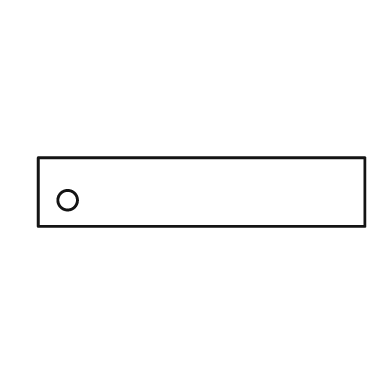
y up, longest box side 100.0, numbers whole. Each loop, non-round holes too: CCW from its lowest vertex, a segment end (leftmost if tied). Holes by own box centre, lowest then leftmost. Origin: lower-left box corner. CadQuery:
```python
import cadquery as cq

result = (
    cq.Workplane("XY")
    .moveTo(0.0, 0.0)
    .lineTo(100.0, 0.0)
    .lineTo(100.0, 21.0)
    .lineTo(0.0, 21.0)
    .close()
    .moveTo(9.0, 8.0)
    .circle(3.0)
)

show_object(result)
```